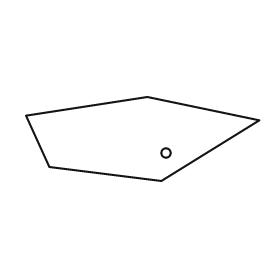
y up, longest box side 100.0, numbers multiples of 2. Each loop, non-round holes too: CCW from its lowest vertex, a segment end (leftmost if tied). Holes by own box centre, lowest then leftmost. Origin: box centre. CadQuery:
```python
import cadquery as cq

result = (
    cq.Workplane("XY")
    .moveTo(8.0, -18.0)
    .lineTo(50.0, 8.0)
    .lineTo(2.0, 18.0)
    .lineTo(-50.0, 10.0)
    .lineTo(-40.0, -12.0)
    .close()
    .moveTo(10.0, -6.0)
    .circle(2.0)
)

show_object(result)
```